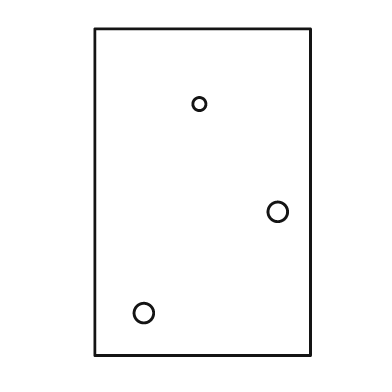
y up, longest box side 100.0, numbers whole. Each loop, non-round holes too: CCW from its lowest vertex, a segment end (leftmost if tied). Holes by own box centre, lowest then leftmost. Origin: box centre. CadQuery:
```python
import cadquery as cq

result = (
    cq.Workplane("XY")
    .moveTo(-33.0, -50.0)
    .lineTo(33.0, -50.0)
    .lineTo(33.0, 50.0)
    .lineTo(-33.0, 50.0)
    .close()
    .moveTo(-18.0, -37.0)
    .circle(3.0)
    .moveTo(23.0, -6.0)
    .circle(3.0)
    .moveTo(-1.0, 27.0)
    .circle(2.0)
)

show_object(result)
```